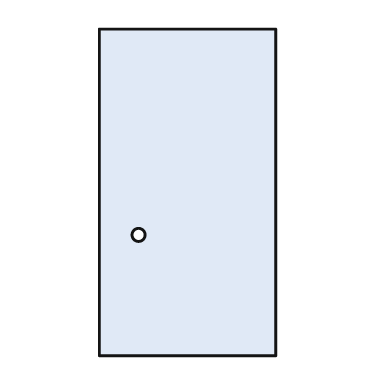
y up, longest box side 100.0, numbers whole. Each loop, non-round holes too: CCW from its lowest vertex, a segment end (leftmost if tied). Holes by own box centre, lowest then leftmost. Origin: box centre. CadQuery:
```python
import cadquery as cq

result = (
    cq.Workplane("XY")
    .moveTo(-27.0, -50.0)
    .lineTo(27.0, -50.0)
    .lineTo(27.0, 50.0)
    .lineTo(-27.0, 50.0)
    .close()
    .moveTo(-15.0, -13.0)
    .circle(2.0)
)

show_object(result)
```